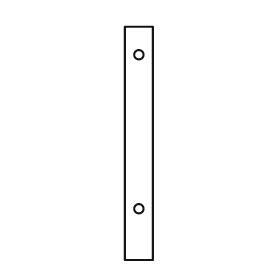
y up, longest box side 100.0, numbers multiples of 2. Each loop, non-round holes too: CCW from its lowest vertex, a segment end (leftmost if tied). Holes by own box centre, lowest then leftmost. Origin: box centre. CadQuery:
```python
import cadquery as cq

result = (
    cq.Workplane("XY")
    .moveTo(-6.0, -50.0)
    .lineTo(6.0, -50.0)
    .lineTo(6.0, 50.0)
    .lineTo(-6.0, 50.0)
    .close()
    .moveTo(0.0, -28.0)
    .circle(2.0)
    .moveTo(0.0, 38.0)
    .circle(2.0)
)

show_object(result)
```